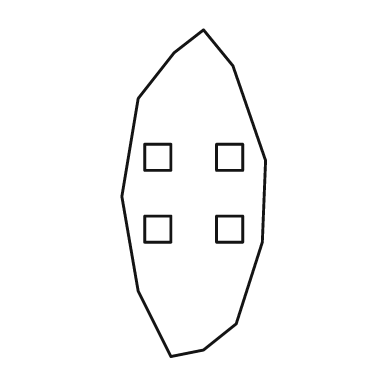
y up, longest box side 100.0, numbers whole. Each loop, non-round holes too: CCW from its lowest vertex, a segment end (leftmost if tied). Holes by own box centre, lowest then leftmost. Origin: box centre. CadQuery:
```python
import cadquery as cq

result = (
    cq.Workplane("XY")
    .moveTo(-7.0, -50.0)
    .lineTo(3.0, -48.0)
    .lineTo(13.0, -40.0)
    .lineTo(21.0, -15.0)
    .lineTo(22.0, 10.0)
    .lineTo(12.0, 39.0)
    .lineTo(3.0, 50.0)
    .lineTo(-6.0, 43.0)
    .lineTo(-17.0, 29.0)
    .lineTo(-22.0, -1.0)
    .lineTo(-17.0, -30.0)
    .close()
    .moveTo(-15.0, -15.0)
    .lineTo(-7.0, -15.0)
    .lineTo(-7.0, -7.0)
    .lineTo(-15.0, -7.0)
    .close()
    .moveTo(7.0, -15.0)
    .lineTo(15.0, -15.0)
    .lineTo(15.0, -7.0)
    .lineTo(7.0, -7.0)
    .close()
    .moveTo(-15.0, 7.0)
    .lineTo(-7.0, 7.0)
    .lineTo(-7.0, 15.0)
    .lineTo(-15.0, 15.0)
    .close()
    .moveTo(7.0, 7.0)
    .lineTo(15.0, 7.0)
    .lineTo(15.0, 15.0)
    .lineTo(7.0, 15.0)
    .close()
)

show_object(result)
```